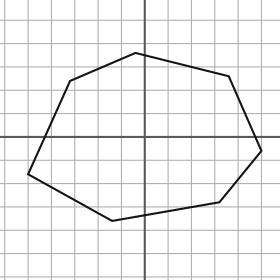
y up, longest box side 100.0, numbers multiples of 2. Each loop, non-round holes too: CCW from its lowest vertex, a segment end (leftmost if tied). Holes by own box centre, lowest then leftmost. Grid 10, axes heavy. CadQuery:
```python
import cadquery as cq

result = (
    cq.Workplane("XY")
    .moveTo(-14.0, -36.0)
    .lineTo(32.0, -28.0)
    .lineTo(50.0, -6.0)
    .lineTo(36.0, 26.0)
    .lineTo(-4.0, 36.0)
    .lineTo(-32.0, 24.0)
    .lineTo(-50.0, -16.0)
    .close()
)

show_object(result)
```